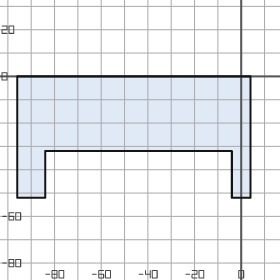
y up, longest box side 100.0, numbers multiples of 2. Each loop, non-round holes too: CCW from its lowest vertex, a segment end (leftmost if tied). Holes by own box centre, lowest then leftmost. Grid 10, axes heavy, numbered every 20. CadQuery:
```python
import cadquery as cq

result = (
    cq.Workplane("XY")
    .moveTo(-96.0, -52.0)
    .lineTo(-84.0, -52.0)
    .lineTo(-84.0, -32.0)
    .lineTo(-4.0, -32.0)
    .lineTo(-4.0, -52.0)
    .lineTo(4.0, -52.0)
    .lineTo(4.0, 0.0)
    .lineTo(-96.0, 0.0)
    .close()
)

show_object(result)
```